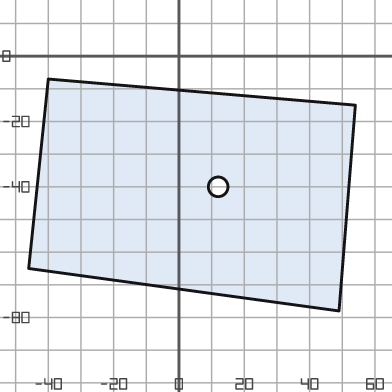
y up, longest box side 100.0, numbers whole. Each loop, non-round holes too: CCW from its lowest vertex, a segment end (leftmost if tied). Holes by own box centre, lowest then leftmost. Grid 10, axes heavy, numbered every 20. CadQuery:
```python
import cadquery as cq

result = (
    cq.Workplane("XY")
    .moveTo(49.0, -78.0)
    .lineTo(54.0, -15.0)
    .lineTo(-40.0, -7.0)
    .lineTo(-46.0, -65.0)
    .close()
    .moveTo(12.0, -40.0)
    .circle(3.0)
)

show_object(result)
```